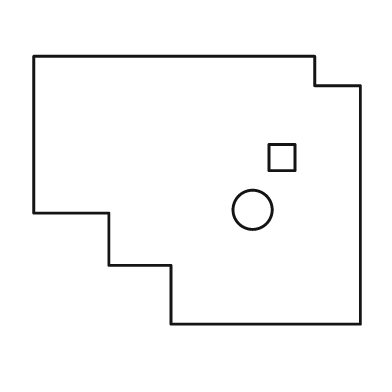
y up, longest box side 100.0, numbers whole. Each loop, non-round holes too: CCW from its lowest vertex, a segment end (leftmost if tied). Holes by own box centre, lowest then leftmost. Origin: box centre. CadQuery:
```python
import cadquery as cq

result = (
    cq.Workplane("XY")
    .moveTo(-8.0, -41.0)
    .lineTo(50.0, -41.0)
    .lineTo(50.0, 32.0)
    .lineTo(36.0, 32.0)
    .lineTo(36.0, 41.0)
    .lineTo(-50.0, 41.0)
    .lineTo(-50.0, -7.0)
    .lineTo(-27.0, -7.0)
    .lineTo(-27.0, -23.0)
    .lineTo(-8.0, -23.0)
    .close()
    .moveTo(17.0, -6.0)
    .circle(6.0)
    .moveTo(22.0, 6.0)
    .lineTo(30.0, 6.0)
    .lineTo(30.0, 14.0)
    .lineTo(22.0, 14.0)
    .close()
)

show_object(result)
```